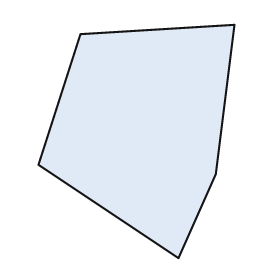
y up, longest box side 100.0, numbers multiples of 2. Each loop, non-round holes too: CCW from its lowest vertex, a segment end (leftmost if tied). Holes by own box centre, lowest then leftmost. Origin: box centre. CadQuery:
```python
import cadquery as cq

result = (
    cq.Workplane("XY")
    .moveTo(18.0, -50.0)
    .lineTo(34.0, -14.0)
    .lineTo(42.0, 50.0)
    .lineTo(-24.0, 46.0)
    .lineTo(-42.0, -10.0)
    .close()
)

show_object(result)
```